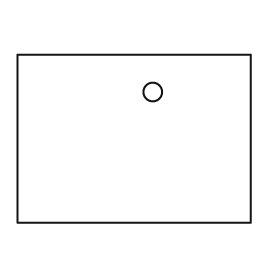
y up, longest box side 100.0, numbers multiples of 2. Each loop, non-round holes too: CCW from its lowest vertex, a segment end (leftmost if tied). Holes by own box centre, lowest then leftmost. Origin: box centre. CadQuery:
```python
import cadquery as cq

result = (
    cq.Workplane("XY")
    .moveTo(-50.0, -36.0)
    .lineTo(50.0, -36.0)
    .lineTo(50.0, 36.0)
    .lineTo(-50.0, 36.0)
    .close()
    .moveTo(8.0, 20.0)
    .circle(4.0)
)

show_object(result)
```